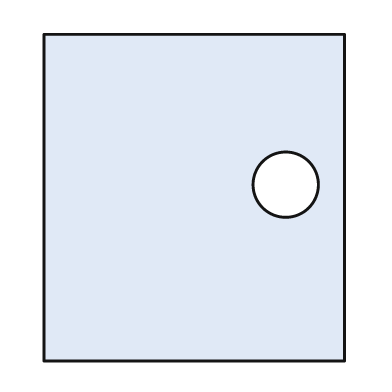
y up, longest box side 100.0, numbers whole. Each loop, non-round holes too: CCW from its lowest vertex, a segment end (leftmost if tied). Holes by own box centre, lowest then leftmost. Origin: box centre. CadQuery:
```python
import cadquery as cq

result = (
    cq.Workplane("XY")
    .moveTo(-46.0, -50.0)
    .lineTo(46.0, -50.0)
    .lineTo(46.0, 50.0)
    .lineTo(-46.0, 50.0)
    .close()
    .moveTo(28.0, 4.0)
    .circle(10.0)
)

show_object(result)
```